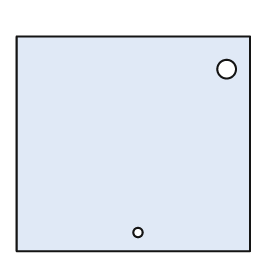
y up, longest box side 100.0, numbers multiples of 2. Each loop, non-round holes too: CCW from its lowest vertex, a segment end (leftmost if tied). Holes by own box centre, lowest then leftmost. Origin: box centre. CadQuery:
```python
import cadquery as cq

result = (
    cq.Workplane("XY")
    .moveTo(-50.0, -46.0)
    .lineTo(50.0, -46.0)
    .lineTo(50.0, 46.0)
    .lineTo(-50.0, 46.0)
    .close()
    .moveTo(2.0, -38.0)
    .circle(2.0)
    .moveTo(40.0, 32.0)
    .circle(4.0)
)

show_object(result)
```